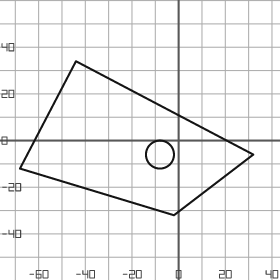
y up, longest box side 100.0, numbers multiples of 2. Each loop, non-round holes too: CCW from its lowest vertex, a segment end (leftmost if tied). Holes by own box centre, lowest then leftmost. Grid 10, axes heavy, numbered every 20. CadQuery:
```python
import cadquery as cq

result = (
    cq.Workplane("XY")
    .moveTo(-2.0, -32.0)
    .lineTo(32.0, -6.0)
    .lineTo(-44.0, 34.0)
    .lineTo(-68.0, -12.0)
    .close()
    .moveTo(-8.0, -6.0)
    .circle(6.0)
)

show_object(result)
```